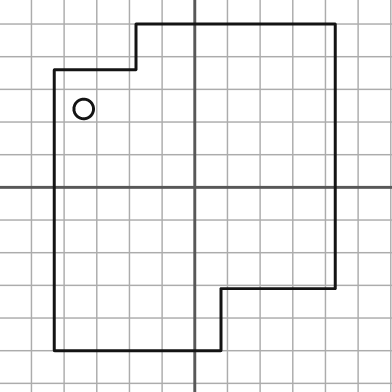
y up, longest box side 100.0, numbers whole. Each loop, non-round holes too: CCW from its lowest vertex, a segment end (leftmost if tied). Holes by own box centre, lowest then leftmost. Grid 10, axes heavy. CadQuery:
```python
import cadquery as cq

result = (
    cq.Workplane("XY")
    .moveTo(-43.0, -50.0)
    .lineTo(8.0, -50.0)
    .lineTo(8.0, -31.0)
    .lineTo(43.0, -31.0)
    .lineTo(43.0, 50.0)
    .lineTo(-18.0, 50.0)
    .lineTo(-18.0, 36.0)
    .lineTo(-43.0, 36.0)
    .close()
    .moveTo(-34.0, 24.0)
    .circle(3.0)
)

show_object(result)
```